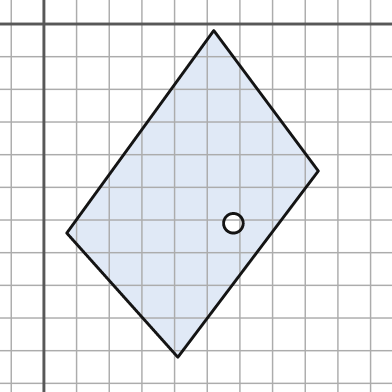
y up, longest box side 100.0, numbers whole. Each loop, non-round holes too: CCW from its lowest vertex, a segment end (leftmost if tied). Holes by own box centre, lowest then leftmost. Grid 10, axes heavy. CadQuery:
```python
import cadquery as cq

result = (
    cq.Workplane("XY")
    .moveTo(41.0, -102.0)
    .lineTo(84.0, -45.0)
    .lineTo(52.0, -2.0)
    .lineTo(7.0, -64.0)
    .close()
    .moveTo(58.0, -61.0)
    .circle(3.0)
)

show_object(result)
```